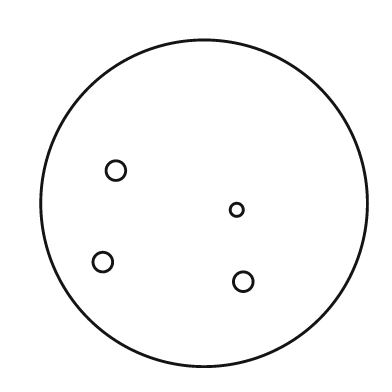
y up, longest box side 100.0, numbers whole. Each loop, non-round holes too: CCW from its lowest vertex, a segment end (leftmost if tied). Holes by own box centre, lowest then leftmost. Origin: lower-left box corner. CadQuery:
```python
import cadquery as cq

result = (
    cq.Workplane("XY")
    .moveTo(50.0, 50.0)
    .circle(50.0)
    .moveTo(62.0, 26.0)
    .circle(3.0)
    .moveTo(19.0, 32.0)
    .circle(3.0)
    .moveTo(60.0, 48.0)
    .circle(2.0)
    .moveTo(23.0, 60.0)
    .circle(3.0)
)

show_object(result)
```